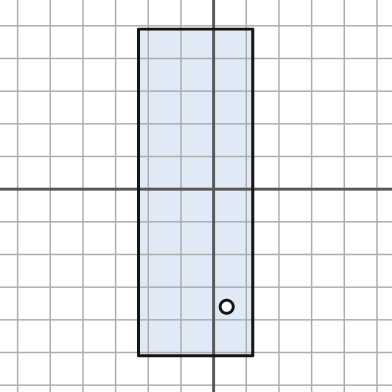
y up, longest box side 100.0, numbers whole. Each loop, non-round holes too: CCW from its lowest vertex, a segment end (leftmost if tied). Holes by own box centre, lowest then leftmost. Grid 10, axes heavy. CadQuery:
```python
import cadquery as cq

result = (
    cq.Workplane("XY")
    .moveTo(-23.0, -51.0)
    .lineTo(12.0, -51.0)
    .lineTo(12.0, 49.0)
    .lineTo(-23.0, 49.0)
    .close()
    .moveTo(4.0, -36.0)
    .circle(2.0)
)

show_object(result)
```